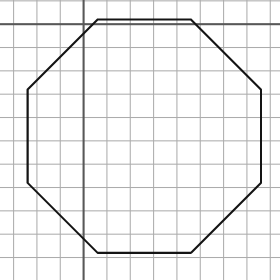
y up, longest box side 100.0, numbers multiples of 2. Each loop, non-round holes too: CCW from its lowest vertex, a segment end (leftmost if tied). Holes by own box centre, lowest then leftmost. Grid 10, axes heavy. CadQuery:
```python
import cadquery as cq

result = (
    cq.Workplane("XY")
    .moveTo(6.0, -98.0)
    .lineTo(46.0, -98.0)
    .lineTo(76.0, -68.0)
    .lineTo(76.0, -28.0)
    .lineTo(46.0, 2.0)
    .lineTo(6.0, 2.0)
    .lineTo(-24.0, -28.0)
    .lineTo(-24.0, -68.0)
    .close()
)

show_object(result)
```